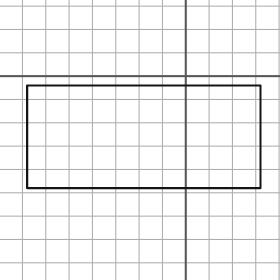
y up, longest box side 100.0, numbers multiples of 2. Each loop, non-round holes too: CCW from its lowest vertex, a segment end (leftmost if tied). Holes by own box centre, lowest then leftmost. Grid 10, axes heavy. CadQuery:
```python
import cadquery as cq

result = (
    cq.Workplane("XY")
    .moveTo(-68.0, -48.0)
    .lineTo(32.0, -48.0)
    .lineTo(32.0, -4.0)
    .lineTo(-68.0, -4.0)
    .close()
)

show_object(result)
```